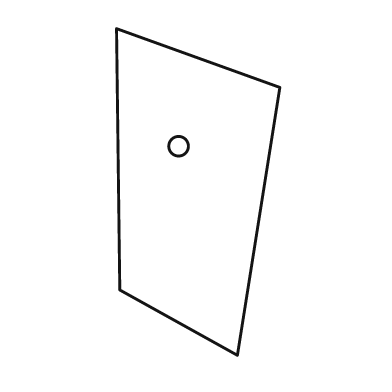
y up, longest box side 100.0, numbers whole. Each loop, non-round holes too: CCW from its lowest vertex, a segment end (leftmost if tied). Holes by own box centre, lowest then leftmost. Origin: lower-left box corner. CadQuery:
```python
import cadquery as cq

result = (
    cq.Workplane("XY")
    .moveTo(37.0, 0.0)
    .lineTo(50.0, 82.0)
    .lineTo(0.0, 100.0)
    .lineTo(1.0, 20.0)
    .close()
    .moveTo(19.0, 64.0)
    .circle(3.0)
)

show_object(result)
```